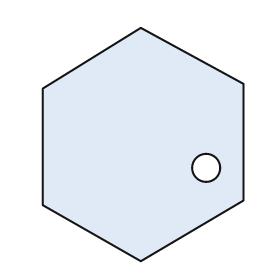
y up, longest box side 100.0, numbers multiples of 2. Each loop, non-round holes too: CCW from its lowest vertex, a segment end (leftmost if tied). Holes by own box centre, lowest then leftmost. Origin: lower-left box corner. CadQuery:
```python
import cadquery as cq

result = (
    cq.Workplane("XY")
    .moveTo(42.0, 0.0)
    .lineTo(86.0, 26.0)
    .lineTo(86.0, 76.0)
    .lineTo(42.0, 100.0)
    .lineTo(0.0, 74.0)
    .lineTo(0.0, 24.0)
    .close()
    .moveTo(70.0, 40.0)
    .circle(6.0)
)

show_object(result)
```